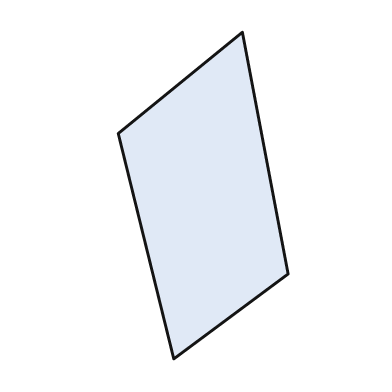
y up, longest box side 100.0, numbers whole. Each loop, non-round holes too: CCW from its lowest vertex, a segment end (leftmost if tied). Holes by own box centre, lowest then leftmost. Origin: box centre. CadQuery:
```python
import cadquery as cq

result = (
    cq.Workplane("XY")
    .moveTo(-9.0, -50.0)
    .lineTo(26.0, -24.0)
    .lineTo(12.0, 50.0)
    .lineTo(-26.0, 19.0)
    .close()
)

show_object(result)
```